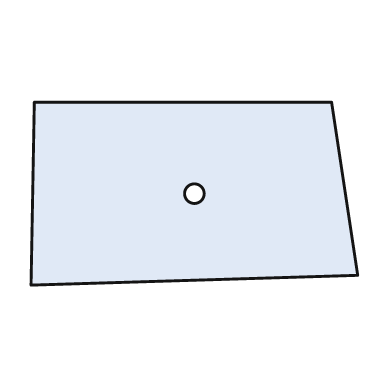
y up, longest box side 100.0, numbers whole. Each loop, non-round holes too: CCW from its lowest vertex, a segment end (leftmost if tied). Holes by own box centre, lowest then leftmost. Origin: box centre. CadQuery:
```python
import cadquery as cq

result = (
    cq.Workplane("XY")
    .moveTo(-50.0, -28.0)
    .lineTo(50.0, -25.0)
    .lineTo(42.0, 28.0)
    .lineTo(-49.0, 28.0)
    .close()
    .moveTo(0.0, 0.0)
    .circle(3.0)
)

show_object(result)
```